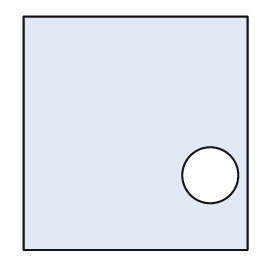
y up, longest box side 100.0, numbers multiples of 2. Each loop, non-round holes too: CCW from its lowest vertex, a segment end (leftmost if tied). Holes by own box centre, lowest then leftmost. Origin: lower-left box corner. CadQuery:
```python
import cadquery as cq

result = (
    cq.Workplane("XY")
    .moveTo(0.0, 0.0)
    .lineTo(96.0, 0.0)
    .lineTo(96.0, 100.0)
    .lineTo(0.0, 100.0)
    .close()
    .moveTo(80.0, 32.0)
    .circle(12.0)
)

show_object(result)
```